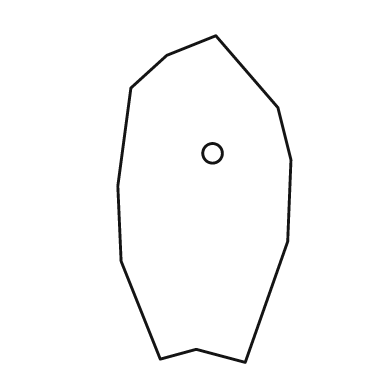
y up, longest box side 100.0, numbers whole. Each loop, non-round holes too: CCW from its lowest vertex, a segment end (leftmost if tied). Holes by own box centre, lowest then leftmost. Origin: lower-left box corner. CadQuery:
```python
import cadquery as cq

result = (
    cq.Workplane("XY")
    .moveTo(39.0, 0.0)
    .lineTo(52.0, 37.0)
    .lineTo(53.0, 62.0)
    .lineTo(49.0, 78.0)
    .lineTo(30.0, 100.0)
    .lineTo(15.0, 94.0)
    .lineTo(4.0, 84.0)
    .lineTo(0.0, 54.0)
    .lineTo(1.0, 31.0)
    .lineTo(13.0, 1.0)
    .lineTo(24.0, 4.0)
    .close()
    .moveTo(29.0, 64.0)
    .circle(3.0)
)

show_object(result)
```